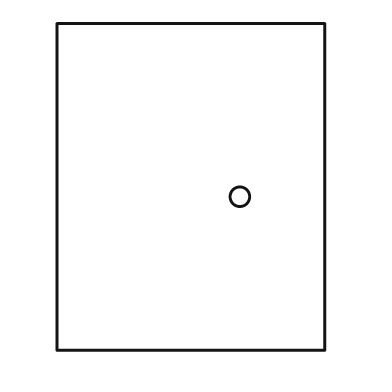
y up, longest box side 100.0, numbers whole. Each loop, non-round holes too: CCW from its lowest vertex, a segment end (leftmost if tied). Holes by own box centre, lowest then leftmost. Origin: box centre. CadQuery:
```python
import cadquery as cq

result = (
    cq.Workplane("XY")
    .moveTo(-41.0, -50.0)
    .lineTo(41.0, -50.0)
    .lineTo(41.0, 50.0)
    .lineTo(-41.0, 50.0)
    .close()
    .moveTo(15.0, -3.0)
    .circle(3.0)
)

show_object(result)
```